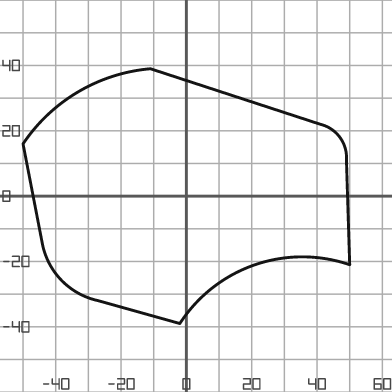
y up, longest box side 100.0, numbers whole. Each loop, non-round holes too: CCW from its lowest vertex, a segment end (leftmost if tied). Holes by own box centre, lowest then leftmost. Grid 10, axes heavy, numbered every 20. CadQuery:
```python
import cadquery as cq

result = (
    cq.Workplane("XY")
    .moveTo(-2.0, -39.0)
    .threePointArc((21.0, -21.0), (50.0, -21.0))
    .lineTo(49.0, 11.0)
    .threePointArc((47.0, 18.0), (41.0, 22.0))
    .lineTo(-11.0, 39.0)
    .threePointArc((-33.0, 32.0), (-50.0, 16.0))
    .lineTo(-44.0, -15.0)
    .threePointArc((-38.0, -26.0), (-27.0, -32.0))
    .close()
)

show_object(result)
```